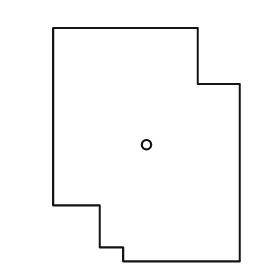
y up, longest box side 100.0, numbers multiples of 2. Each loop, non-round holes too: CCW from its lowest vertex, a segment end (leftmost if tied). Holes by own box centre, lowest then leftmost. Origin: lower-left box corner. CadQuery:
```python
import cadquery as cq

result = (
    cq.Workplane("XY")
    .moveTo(30.0, 0.0)
    .lineTo(80.0, 0.0)
    .lineTo(80.0, 76.0)
    .lineTo(62.0, 76.0)
    .lineTo(62.0, 100.0)
    .lineTo(0.0, 100.0)
    .lineTo(0.0, 24.0)
    .lineTo(20.0, 24.0)
    .lineTo(20.0, 6.0)
    .lineTo(30.0, 6.0)
    .close()
    .moveTo(40.0, 50.0)
    .circle(2.0)
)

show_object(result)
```